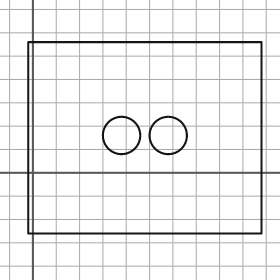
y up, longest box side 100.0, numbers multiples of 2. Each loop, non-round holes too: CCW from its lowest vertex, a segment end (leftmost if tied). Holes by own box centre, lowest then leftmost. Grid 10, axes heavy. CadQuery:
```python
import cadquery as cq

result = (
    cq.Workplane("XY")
    .moveTo(-2.0, -26.0)
    .lineTo(98.0, -26.0)
    .lineTo(98.0, 56.0)
    .lineTo(-2.0, 56.0)
    .close()
    .moveTo(38.0, 16.0)
    .circle(8.0)
    .moveTo(58.0, 16.0)
    .circle(8.0)
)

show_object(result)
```